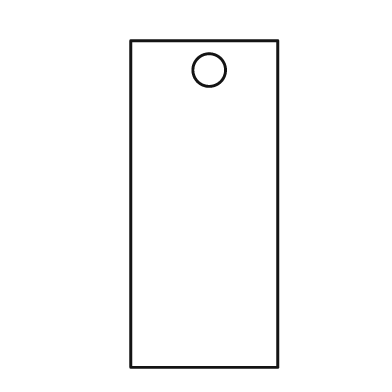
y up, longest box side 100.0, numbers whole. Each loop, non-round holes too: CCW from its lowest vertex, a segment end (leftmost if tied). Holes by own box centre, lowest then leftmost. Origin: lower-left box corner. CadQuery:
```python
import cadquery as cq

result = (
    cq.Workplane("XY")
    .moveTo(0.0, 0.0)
    .lineTo(45.0, 0.0)
    .lineTo(45.0, 100.0)
    .lineTo(0.0, 100.0)
    .close()
    .moveTo(24.0, 91.0)
    .circle(5.0)
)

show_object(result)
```